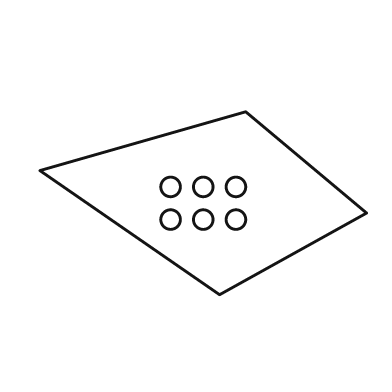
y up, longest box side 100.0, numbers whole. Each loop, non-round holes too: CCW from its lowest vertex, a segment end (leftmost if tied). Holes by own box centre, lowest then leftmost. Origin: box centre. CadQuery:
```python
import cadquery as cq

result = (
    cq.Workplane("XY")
    .moveTo(5.0, -28.0)
    .lineTo(50.0, -3.0)
    .lineTo(13.0, 28.0)
    .lineTo(-50.0, 10.0)
    .close()
    .moveTo(-10.0, -5.0)
    .circle(3.0)
    .moveTo(0.0, -5.0)
    .circle(3.0)
    .moveTo(10.0, -5.0)
    .circle(3.0)
    .moveTo(-10.0, 5.0)
    .circle(3.0)
    .moveTo(0.0, 5.0)
    .circle(3.0)
    .moveTo(10.0, 5.0)
    .circle(3.0)
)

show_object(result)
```